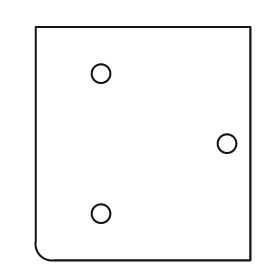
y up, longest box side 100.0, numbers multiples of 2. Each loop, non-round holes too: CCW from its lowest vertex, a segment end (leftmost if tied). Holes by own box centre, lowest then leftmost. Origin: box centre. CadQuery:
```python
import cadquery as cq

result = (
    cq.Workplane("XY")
    .moveTo(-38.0, -50.0)
    .lineTo(46.0, -50.0)
    .lineTo(46.0, 50.0)
    .lineTo(-46.0, 50.0)
    .lineTo(-46.0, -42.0)
    .threePointArc((-44.0, -48.0), (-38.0, -50.0))
    .close()
    .moveTo(-18.0, -30.0)
    .circle(4.0)
    .moveTo(36.0, 0.0)
    .circle(4.0)
    .moveTo(-18.0, 30.0)
    .circle(4.0)
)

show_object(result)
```